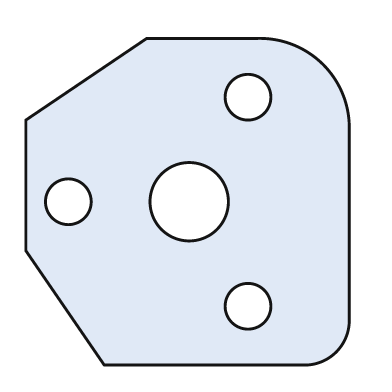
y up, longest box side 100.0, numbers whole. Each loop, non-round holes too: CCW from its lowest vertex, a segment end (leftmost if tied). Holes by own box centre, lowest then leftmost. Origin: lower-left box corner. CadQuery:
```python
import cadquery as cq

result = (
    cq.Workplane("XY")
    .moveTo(24.0, 0.0)
    .lineTo(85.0, 0.0)
    .threePointArc((95.0, 4.0), (99.0, 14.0))
    .lineTo(99.0, 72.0)
    .threePointArc((91.0, 92.0), (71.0, 100.0))
    .lineTo(37.0, 100.0)
    .lineTo(0.0, 75.0)
    .lineTo(0.0, 35.0)
    .close()
    .moveTo(68.0, 18.0)
    .circle(7.0)
    .moveTo(13.0, 50.0)
    .circle(7.0)
    .moveTo(50.0, 50.0)
    .circle(12.0)
    .moveTo(68.0, 82.0)
    .circle(7.0)
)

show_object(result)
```